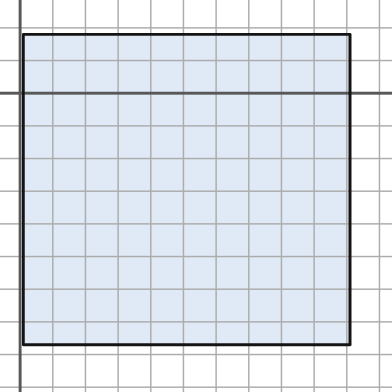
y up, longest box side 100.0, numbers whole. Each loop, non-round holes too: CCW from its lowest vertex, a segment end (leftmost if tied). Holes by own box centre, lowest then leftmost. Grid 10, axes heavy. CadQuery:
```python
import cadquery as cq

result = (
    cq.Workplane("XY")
    .moveTo(1.0, -77.0)
    .lineTo(101.0, -77.0)
    .lineTo(101.0, 18.0)
    .lineTo(1.0, 18.0)
    .close()
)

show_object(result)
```